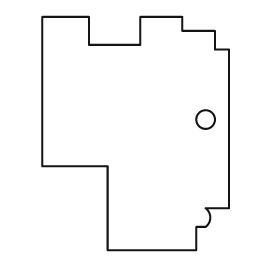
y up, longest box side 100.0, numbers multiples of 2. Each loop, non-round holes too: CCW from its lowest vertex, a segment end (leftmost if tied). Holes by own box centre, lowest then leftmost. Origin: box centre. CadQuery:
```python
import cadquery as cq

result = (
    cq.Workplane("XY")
    .moveTo(-12.0, -50.0)
    .lineTo(26.0, -50.0)
    .lineTo(26.0, -40.0)
    .lineTo(30.0, -40.0)
    .threePointArc((32.0, -36.0), (30.0, -32.0))
    .lineTo(40.0, -32.0)
    .lineTo(40.0, 36.0)
    .lineTo(34.0, 36.0)
    .lineTo(34.0, 44.0)
    .lineTo(20.0, 44.0)
    .lineTo(20.0, 50.0)
    .lineTo(2.0, 50.0)
    .lineTo(2.0, 38.0)
    .lineTo(-20.0, 38.0)
    .lineTo(-20.0, 50.0)
    .lineTo(-40.0, 50.0)
    .lineTo(-40.0, -14.0)
    .lineTo(-12.0, -14.0)
    .close()
    .moveTo(30.0, 6.0)
    .circle(4.0)
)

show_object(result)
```